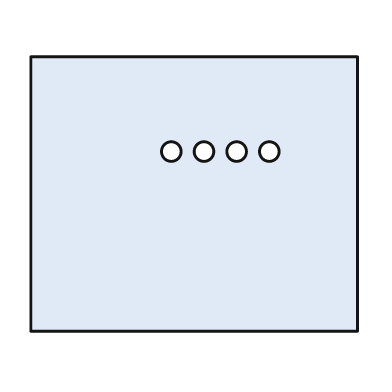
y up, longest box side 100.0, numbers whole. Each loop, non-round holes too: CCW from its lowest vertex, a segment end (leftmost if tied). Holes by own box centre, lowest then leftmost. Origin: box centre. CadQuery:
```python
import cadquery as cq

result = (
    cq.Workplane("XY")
    .moveTo(-50.0, -42.0)
    .lineTo(50.0, -42.0)
    .lineTo(50.0, 42.0)
    .lineTo(-50.0, 42.0)
    .close()
    .moveTo(-7.0, 13.0)
    .circle(3.0)
    .moveTo(3.0, 13.0)
    .circle(3.0)
    .moveTo(13.0, 13.0)
    .circle(3.0)
    .moveTo(23.0, 13.0)
    .circle(3.0)
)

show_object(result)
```